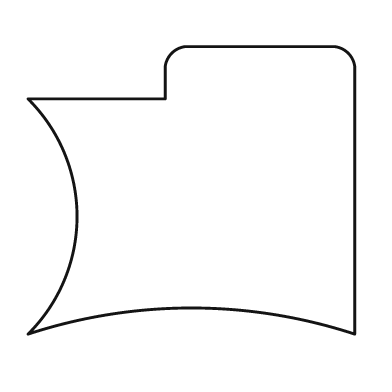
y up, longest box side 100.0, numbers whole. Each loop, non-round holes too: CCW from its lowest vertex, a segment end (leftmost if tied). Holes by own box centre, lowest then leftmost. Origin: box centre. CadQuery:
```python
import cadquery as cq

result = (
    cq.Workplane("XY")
    .moveTo(-50.0, -44.0)
    .threePointArc((0.0, -36.0), (50.0, -44.0))
    .lineTo(50.0, 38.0)
    .threePointArc((48.0, 42.0), (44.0, 44.0))
    .lineTo(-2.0, 44.0)
    .threePointArc((-6.0, 42.0), (-8.0, 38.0))
    .lineTo(-8.0, 28.0)
    .lineTo(-50.0, 28.0)
    .threePointArc((-35.0, -8.0), (-50.0, -44.0))
    .close()
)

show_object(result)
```